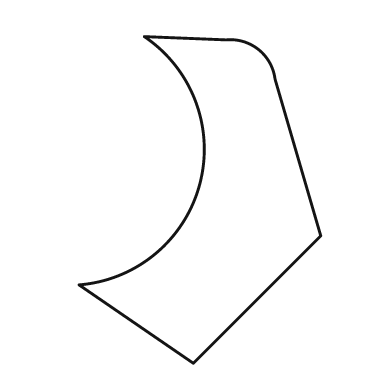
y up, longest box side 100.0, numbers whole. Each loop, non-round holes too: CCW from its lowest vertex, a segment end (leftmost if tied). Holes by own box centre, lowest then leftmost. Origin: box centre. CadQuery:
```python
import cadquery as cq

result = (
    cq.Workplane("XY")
    .moveTo(-2.0, -50.0)
    .lineTo(37.0, -11.0)
    .lineTo(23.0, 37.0)
    .threePointArc((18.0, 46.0), (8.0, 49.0))
    .lineTo(-17.0, 50.0)
    .threePointArc((0.0, 5.0), (-37.0, -26.0))
    .close()
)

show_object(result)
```